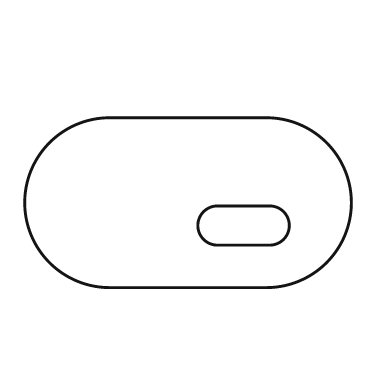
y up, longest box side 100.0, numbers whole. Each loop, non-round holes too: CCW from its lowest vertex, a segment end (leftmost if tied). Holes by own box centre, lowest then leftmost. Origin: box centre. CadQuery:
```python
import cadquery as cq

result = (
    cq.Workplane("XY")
    .moveTo(-24.0, -26.0)
    .lineTo(24.0, -26.0)
    .threePointArc((50.0, 0.0), (24.0, 26.0))
    .lineTo(-24.0, 26.0)
    .threePointArc((-50.0, 0.0), (-24.0, -26.0))
    .close()
    .moveTo(9.0, -13.0)
    .lineTo(25.0, -13.0)
    .threePointArc((31.0, -7.0), (25.0, -1.0))
    .lineTo(9.0, -1.0)
    .threePointArc((3.0, -7.0), (9.0, -13.0))
    .close()
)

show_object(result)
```